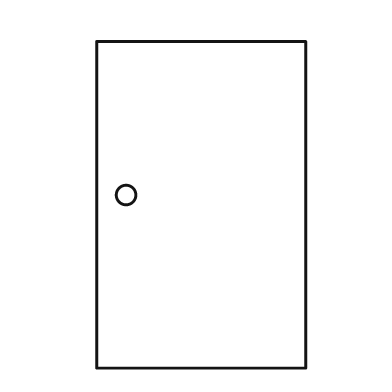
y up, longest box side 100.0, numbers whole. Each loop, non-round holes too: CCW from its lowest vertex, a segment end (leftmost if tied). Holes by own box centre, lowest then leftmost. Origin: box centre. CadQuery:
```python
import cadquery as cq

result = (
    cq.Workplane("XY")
    .moveTo(-32.0, -50.0)
    .lineTo(32.0, -50.0)
    .lineTo(32.0, 50.0)
    .lineTo(-32.0, 50.0)
    .close()
    .moveTo(-23.0, 3.0)
    .circle(3.0)
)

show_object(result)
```